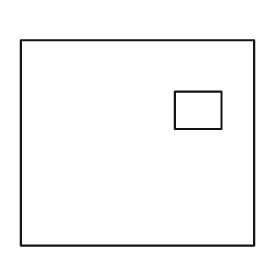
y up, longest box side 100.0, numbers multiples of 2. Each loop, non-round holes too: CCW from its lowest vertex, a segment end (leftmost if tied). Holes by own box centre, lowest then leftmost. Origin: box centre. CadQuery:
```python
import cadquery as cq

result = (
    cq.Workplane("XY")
    .moveTo(-50.0, -44.0)
    .lineTo(50.0, -44.0)
    .lineTo(50.0, 44.0)
    .lineTo(-50.0, 44.0)
    .close()
    .moveTo(16.0, 6.0)
    .lineTo(36.0, 6.0)
    .lineTo(36.0, 22.0)
    .lineTo(16.0, 22.0)
    .close()
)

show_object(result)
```